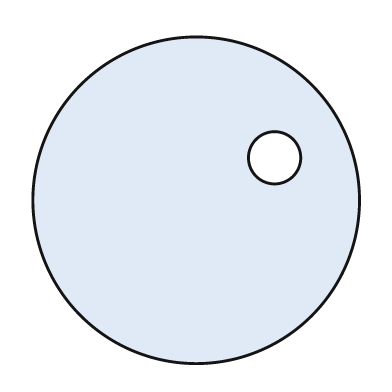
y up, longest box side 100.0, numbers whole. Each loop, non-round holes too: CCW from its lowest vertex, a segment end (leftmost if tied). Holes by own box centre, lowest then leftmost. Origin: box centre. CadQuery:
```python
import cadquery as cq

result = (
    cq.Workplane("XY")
    .moveTo(0.0, 0.0)
    .circle(50.0)
    .moveTo(24.0, 13.0)
    .circle(8.0)
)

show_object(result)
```